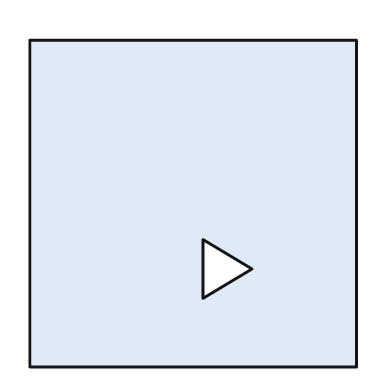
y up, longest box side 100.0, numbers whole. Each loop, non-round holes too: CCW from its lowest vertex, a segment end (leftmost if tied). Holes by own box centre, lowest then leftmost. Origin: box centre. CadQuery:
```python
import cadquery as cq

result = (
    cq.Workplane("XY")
    .moveTo(-50.0, -50.0)
    .lineTo(50.0, -50.0)
    .lineTo(50.0, 50.0)
    .lineTo(-50.0, 50.0)
    .close()
    .moveTo(3.0, -29.0)
    .lineTo(18.0, -20.0)
    .lineTo(3.0, -11.0)
    .close()
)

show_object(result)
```